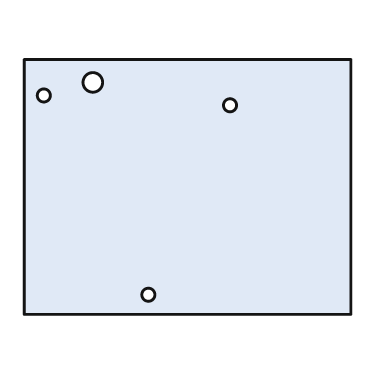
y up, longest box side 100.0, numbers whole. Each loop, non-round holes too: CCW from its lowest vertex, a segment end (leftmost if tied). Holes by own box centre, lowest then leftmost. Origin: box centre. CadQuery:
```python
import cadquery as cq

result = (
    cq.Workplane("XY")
    .moveTo(-50.0, -39.0)
    .lineTo(50.0, -39.0)
    .lineTo(50.0, 39.0)
    .lineTo(-50.0, 39.0)
    .close()
    .moveTo(-12.0, -33.0)
    .circle(2.0)
    .moveTo(13.0, 25.0)
    .circle(2.0)
    .moveTo(-44.0, 28.0)
    .circle(2.0)
    .moveTo(-29.0, 32.0)
    .circle(3.0)
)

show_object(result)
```